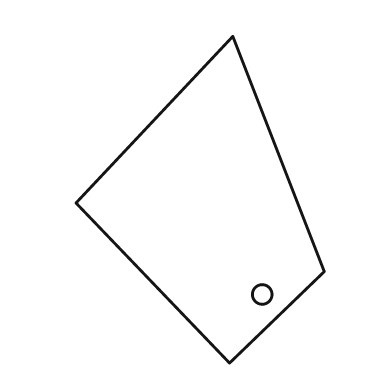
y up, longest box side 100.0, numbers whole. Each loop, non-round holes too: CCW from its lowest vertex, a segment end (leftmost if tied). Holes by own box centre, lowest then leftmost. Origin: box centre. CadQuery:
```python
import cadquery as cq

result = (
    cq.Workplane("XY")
    .moveTo(9.0, -50.0)
    .lineTo(38.0, -22.0)
    .lineTo(10.0, 50.0)
    .lineTo(-38.0, -1.0)
    .close()
    .moveTo(19.0, -29.0)
    .circle(3.0)
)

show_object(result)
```